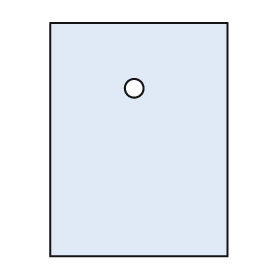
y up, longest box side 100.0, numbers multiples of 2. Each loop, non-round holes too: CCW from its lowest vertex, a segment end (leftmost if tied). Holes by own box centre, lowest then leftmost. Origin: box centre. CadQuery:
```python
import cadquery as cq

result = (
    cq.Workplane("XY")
    .moveTo(-38.0, -50.0)
    .lineTo(38.0, -50.0)
    .lineTo(38.0, 50.0)
    .lineTo(-38.0, 50.0)
    .close()
    .moveTo(-2.0, 22.0)
    .circle(4.0)
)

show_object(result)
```